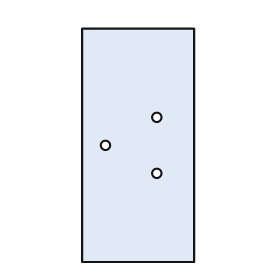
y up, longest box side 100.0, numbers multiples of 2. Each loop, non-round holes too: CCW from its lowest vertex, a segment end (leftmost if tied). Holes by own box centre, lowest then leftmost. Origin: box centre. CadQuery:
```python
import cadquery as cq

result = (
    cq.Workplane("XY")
    .moveTo(-24.0, -50.0)
    .lineTo(24.0, -50.0)
    .lineTo(24.0, 50.0)
    .lineTo(-24.0, 50.0)
    .close()
    .moveTo(8.0, -12.0)
    .circle(2.0)
    .moveTo(-14.0, 0.0)
    .circle(2.0)
    .moveTo(8.0, 12.0)
    .circle(2.0)
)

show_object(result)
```